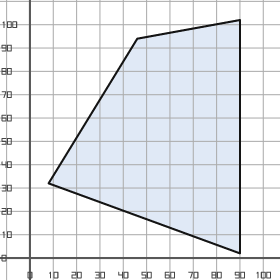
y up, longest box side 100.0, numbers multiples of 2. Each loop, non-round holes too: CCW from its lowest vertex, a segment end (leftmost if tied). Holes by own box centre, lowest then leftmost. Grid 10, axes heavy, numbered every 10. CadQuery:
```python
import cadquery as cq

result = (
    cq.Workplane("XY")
    .moveTo(90.0, 2.0)
    .lineTo(90.0, 102.0)
    .lineTo(46.0, 94.0)
    .lineTo(8.0, 32.0)
    .close()
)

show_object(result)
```